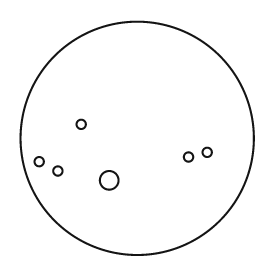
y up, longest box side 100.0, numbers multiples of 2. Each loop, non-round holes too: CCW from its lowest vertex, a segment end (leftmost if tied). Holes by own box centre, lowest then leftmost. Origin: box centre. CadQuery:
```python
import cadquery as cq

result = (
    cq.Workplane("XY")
    .moveTo(0.0, 0.0)
    .circle(50.0)
    .moveTo(-12.0, -18.0)
    .circle(4.0)
    .moveTo(-34.0, -14.0)
    .circle(2.0)
    .moveTo(-42.0, -10.0)
    .circle(2.0)
    .moveTo(22.0, -8.0)
    .circle(2.0)
    .moveTo(30.0, -6.0)
    .circle(2.0)
    .moveTo(-24.0, 6.0)
    .circle(2.0)
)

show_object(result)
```